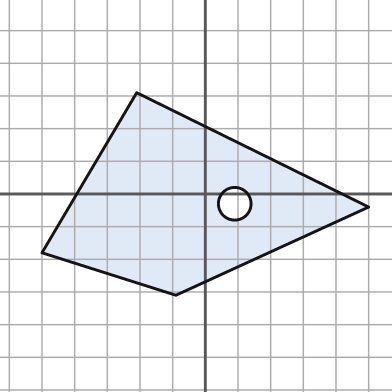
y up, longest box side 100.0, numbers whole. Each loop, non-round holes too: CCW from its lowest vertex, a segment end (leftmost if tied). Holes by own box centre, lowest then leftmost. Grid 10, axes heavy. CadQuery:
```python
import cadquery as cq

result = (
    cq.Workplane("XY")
    .moveTo(-9.0, -31.0)
    .lineTo(50.0, -4.0)
    .lineTo(-21.0, 31.0)
    .lineTo(-50.0, -18.0)
    .close()
    .moveTo(9.0, -3.0)
    .circle(5.0)
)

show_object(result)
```